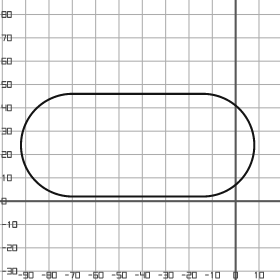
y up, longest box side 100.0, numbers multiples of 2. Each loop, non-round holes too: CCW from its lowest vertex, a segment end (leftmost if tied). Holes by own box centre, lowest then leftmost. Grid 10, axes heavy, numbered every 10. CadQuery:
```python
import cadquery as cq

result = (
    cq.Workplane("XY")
    .moveTo(-70.0, 2.0)
    .lineTo(-14.0, 2.0)
    .threePointArc((8.0, 24.0), (-14.0, 46.0))
    .lineTo(-70.0, 46.0)
    .threePointArc((-92.0, 24.0), (-70.0, 2.0))
    .close()
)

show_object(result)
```